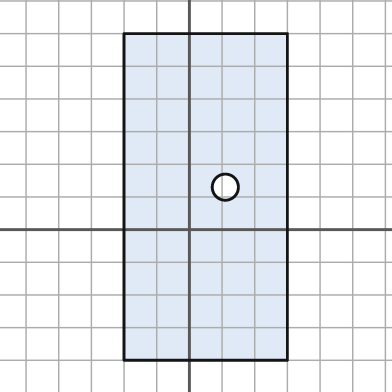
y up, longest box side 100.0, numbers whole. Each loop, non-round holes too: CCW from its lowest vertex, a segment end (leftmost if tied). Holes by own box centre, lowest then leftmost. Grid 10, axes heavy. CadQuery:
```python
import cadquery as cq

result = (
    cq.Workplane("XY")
    .moveTo(-20.0, -40.0)
    .lineTo(30.0, -40.0)
    .lineTo(30.0, 60.0)
    .lineTo(-20.0, 60.0)
    .close()
    .moveTo(11.0, 13.0)
    .circle(4.0)
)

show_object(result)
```